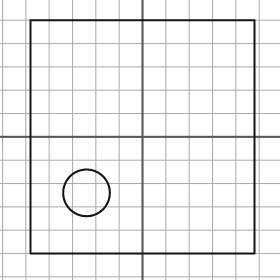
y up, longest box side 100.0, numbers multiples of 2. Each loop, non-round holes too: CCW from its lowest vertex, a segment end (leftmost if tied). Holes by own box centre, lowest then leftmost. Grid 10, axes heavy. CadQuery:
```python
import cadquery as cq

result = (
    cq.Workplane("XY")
    .moveTo(-48.0, -50.0)
    .lineTo(48.0, -50.0)
    .lineTo(48.0, 50.0)
    .lineTo(-48.0, 50.0)
    .close()
    .moveTo(-24.0, -24.0)
    .circle(10.0)
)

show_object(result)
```